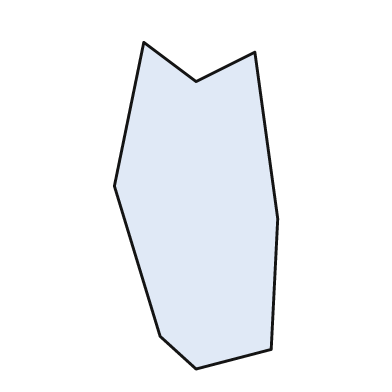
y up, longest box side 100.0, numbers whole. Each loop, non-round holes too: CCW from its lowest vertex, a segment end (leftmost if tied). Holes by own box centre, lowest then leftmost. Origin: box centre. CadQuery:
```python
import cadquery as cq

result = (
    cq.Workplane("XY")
    .moveTo(0.0, -50.0)
    .lineTo(23.0, -44.0)
    .lineTo(25.0, -4.0)
    .lineTo(18.0, 47.0)
    .lineTo(0.0, 38.0)
    .lineTo(-16.0, 50.0)
    .lineTo(-25.0, 6.0)
    .lineTo(-11.0, -40.0)
    .close()
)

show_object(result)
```